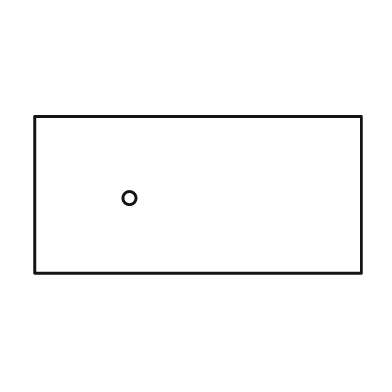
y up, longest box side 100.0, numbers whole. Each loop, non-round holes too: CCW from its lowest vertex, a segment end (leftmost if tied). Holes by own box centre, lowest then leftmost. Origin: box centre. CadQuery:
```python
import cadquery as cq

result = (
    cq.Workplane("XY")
    .moveTo(-50.0, -24.0)
    .lineTo(50.0, -24.0)
    .lineTo(50.0, 24.0)
    .lineTo(-50.0, 24.0)
    .close()
    .moveTo(-21.0, -1.0)
    .circle(2.0)
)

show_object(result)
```